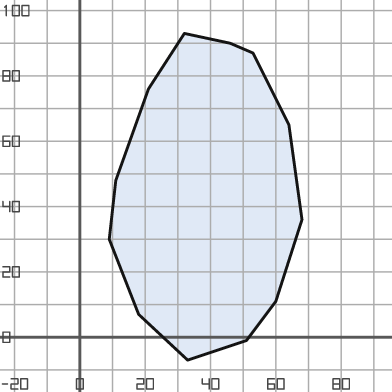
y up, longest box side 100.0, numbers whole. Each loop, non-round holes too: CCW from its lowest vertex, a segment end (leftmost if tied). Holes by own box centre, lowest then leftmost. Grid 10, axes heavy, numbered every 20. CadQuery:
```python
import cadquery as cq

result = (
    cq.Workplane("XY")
    .moveTo(33.0, -7.0)
    .lineTo(51.0, -1.0)
    .lineTo(60.0, 11.0)
    .lineTo(68.0, 36.0)
    .lineTo(64.0, 65.0)
    .lineTo(53.0, 87.0)
    .lineTo(46.0, 90.0)
    .lineTo(32.0, 93.0)
    .lineTo(21.0, 76.0)
    .lineTo(11.0, 48.0)
    .lineTo(9.0, 30.0)
    .lineTo(18.0, 7.0)
    .close()
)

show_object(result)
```